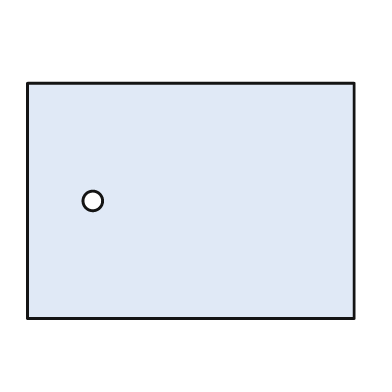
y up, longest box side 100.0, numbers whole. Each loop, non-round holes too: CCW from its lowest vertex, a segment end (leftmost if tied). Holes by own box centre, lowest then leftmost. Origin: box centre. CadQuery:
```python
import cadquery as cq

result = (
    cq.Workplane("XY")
    .moveTo(-50.0, -36.0)
    .lineTo(50.0, -36.0)
    .lineTo(50.0, 36.0)
    .lineTo(-50.0, 36.0)
    .close()
    .moveTo(-30.0, 0.0)
    .circle(3.0)
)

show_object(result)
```